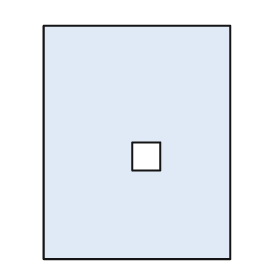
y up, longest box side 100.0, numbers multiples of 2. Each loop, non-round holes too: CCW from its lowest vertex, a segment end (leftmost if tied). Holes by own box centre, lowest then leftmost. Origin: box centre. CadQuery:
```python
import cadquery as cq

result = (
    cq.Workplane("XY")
    .moveTo(-40.0, -50.0)
    .lineTo(40.0, -50.0)
    .lineTo(40.0, 50.0)
    .lineTo(-40.0, 50.0)
    .close()
    .moveTo(-2.0, -12.0)
    .lineTo(10.0, -12.0)
    .lineTo(10.0, 0.0)
    .lineTo(-2.0, 0.0)
    .close()
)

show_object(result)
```